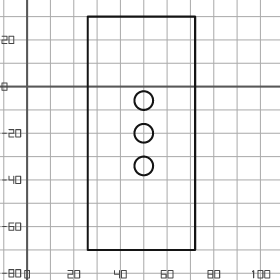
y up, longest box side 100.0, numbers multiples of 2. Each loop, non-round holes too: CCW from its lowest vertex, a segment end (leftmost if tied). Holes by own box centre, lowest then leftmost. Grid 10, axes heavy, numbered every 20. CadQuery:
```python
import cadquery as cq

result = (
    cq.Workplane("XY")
    .moveTo(26.0, -70.0)
    .lineTo(72.0, -70.0)
    .lineTo(72.0, 30.0)
    .lineTo(26.0, 30.0)
    .close()
    .moveTo(50.0, -34.0)
    .circle(4.0)
    .moveTo(50.0, -20.0)
    .circle(4.0)
    .moveTo(50.0, -6.0)
    .circle(4.0)
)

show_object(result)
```